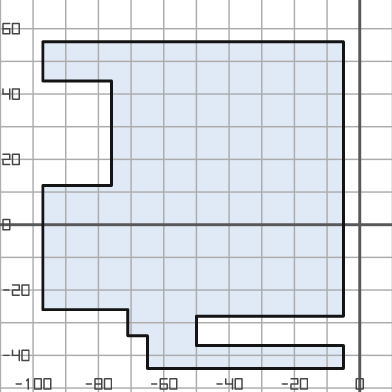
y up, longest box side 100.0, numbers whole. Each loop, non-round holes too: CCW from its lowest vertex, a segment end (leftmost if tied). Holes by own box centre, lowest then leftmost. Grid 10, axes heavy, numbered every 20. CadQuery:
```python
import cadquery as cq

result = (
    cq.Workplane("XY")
    .moveTo(-65.0, -44.0)
    .lineTo(-5.0, -44.0)
    .lineTo(-5.0, -37.0)
    .lineTo(-50.0, -37.0)
    .lineTo(-50.0, -28.0)
    .lineTo(-5.0, -28.0)
    .lineTo(-5.0, 56.0)
    .lineTo(-97.0, 56.0)
    .lineTo(-97.0, 44.0)
    .lineTo(-76.0, 44.0)
    .lineTo(-76.0, 12.0)
    .lineTo(-97.0, 12.0)
    .lineTo(-97.0, -26.0)
    .lineTo(-71.0, -26.0)
    .lineTo(-71.0, -34.0)
    .lineTo(-65.0, -34.0)
    .close()
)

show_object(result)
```